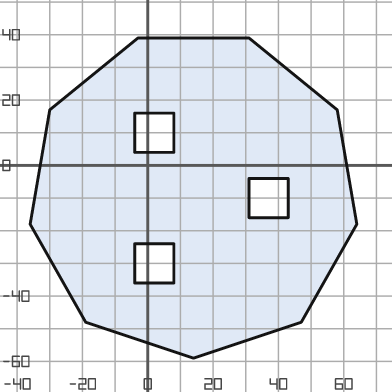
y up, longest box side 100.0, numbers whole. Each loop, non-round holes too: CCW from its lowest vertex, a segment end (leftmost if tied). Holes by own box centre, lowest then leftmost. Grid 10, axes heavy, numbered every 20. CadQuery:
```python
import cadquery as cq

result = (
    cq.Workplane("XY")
    .moveTo(14.0, -59.0)
    .lineTo(47.0, -48.0)
    .lineTo(64.0, -18.0)
    .lineTo(58.0, 17.0)
    .lineTo(31.0, 39.0)
    .lineTo(-3.0, 39.0)
    .lineTo(-30.0, 17.0)
    .lineTo(-36.0, -18.0)
    .lineTo(-19.0, -48.0)
    .close()
    .moveTo(-4.0, -36.0)
    .lineTo(8.0, -36.0)
    .lineTo(8.0, -24.0)
    .lineTo(-4.0, -24.0)
    .close()
    .moveTo(31.0, -16.0)
    .lineTo(43.0, -16.0)
    .lineTo(43.0, -4.0)
    .lineTo(31.0, -4.0)
    .close()
    .moveTo(-4.0, 4.0)
    .lineTo(8.0, 4.0)
    .lineTo(8.0, 16.0)
    .lineTo(-4.0, 16.0)
    .close()
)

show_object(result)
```